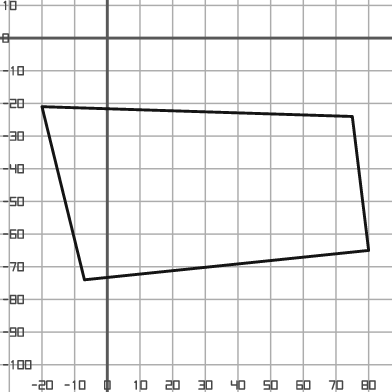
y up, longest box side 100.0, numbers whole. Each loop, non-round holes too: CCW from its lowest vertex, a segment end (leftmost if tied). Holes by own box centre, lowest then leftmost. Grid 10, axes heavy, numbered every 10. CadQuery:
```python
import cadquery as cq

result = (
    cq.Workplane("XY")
    .moveTo(-7.0, -74.0)
    .lineTo(80.0, -65.0)
    .lineTo(75.0, -24.0)
    .lineTo(-20.0, -21.0)
    .close()
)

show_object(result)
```